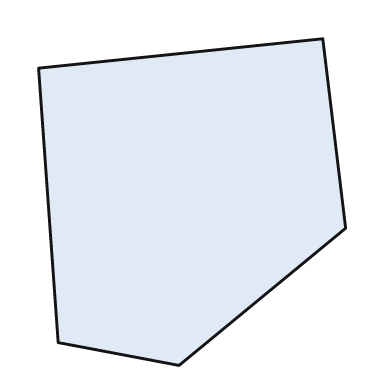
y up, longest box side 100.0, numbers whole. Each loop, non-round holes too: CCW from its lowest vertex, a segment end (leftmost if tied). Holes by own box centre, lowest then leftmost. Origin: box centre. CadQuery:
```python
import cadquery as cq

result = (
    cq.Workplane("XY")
    .moveTo(-4.0, -50.0)
    .lineTo(47.0, -8.0)
    .lineTo(40.0, 50.0)
    .lineTo(-47.0, 41.0)
    .lineTo(-41.0, -43.0)
    .close()
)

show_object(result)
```